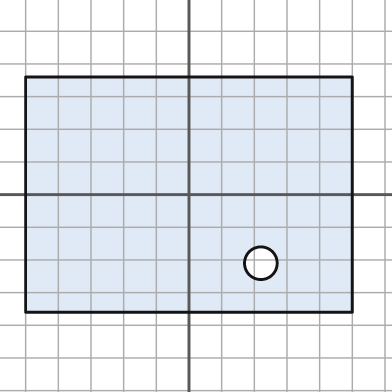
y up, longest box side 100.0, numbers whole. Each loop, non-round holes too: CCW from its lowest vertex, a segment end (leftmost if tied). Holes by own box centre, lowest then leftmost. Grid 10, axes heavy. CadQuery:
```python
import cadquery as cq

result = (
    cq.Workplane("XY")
    .moveTo(-50.0, -36.0)
    .lineTo(50.0, -36.0)
    .lineTo(50.0, 36.0)
    .lineTo(-50.0, 36.0)
    .close()
    .moveTo(22.0, -21.0)
    .circle(5.0)
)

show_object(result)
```